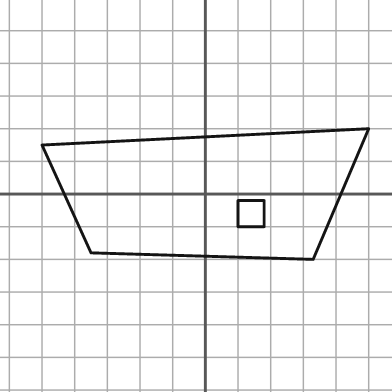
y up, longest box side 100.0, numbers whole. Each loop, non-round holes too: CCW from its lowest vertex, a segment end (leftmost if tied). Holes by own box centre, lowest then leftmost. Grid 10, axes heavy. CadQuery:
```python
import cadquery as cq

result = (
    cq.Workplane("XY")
    .moveTo(33.0, -20.0)
    .lineTo(50.0, 20.0)
    .lineTo(-50.0, 15.0)
    .lineTo(-35.0, -18.0)
    .close()
    .moveTo(10.0, -10.0)
    .lineTo(18.0, -10.0)
    .lineTo(18.0, -2.0)
    .lineTo(10.0, -2.0)
    .close()
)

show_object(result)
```